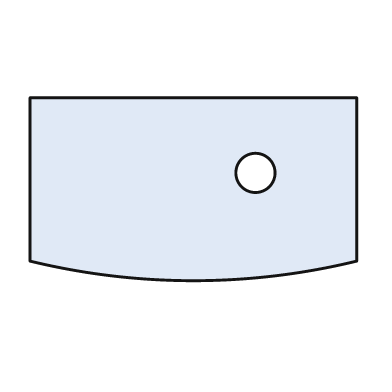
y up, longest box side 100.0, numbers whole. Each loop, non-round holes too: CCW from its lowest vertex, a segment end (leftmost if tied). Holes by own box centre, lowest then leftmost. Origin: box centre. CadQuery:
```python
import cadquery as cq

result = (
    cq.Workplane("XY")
    .moveTo(-50.0, -22.0)
    .threePointArc((0.0, -28.0), (50.0, -22.0))
    .lineTo(50.0, 28.0)
    .lineTo(-50.0, 28.0)
    .close()
    .moveTo(19.0, 5.0)
    .circle(6.0)
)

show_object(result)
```